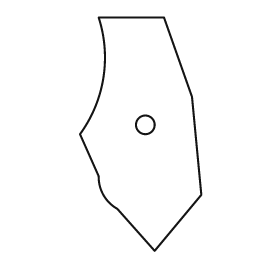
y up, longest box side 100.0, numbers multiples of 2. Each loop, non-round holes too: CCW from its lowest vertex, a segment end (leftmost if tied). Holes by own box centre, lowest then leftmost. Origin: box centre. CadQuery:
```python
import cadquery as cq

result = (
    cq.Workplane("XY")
    .moveTo(6.0, -50.0)
    .lineTo(26.0, -26.0)
    .lineTo(22.0, 16.0)
    .lineTo(10.0, 50.0)
    .lineTo(-18.0, 50.0)
    .threePointArc((-16.0, 24.0), (-26.0, 0.0))
    .lineTo(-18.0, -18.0)
    .threePointArc((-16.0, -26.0), (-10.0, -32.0))
    .close()
    .moveTo(2.0, 4.0)
    .circle(4.0)
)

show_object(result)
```